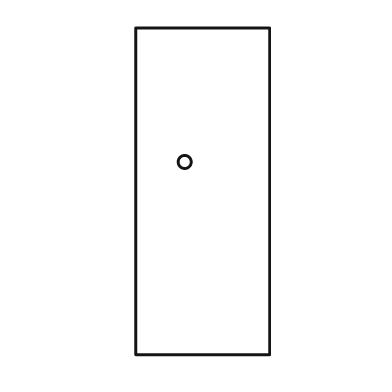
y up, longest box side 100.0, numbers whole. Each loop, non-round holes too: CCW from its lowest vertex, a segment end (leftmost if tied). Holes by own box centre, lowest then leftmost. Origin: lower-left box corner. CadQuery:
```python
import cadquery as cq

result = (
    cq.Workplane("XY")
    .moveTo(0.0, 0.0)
    .lineTo(41.0, 0.0)
    .lineTo(41.0, 100.0)
    .lineTo(0.0, 100.0)
    .close()
    .moveTo(15.0, 59.0)
    .circle(2.0)
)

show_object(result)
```